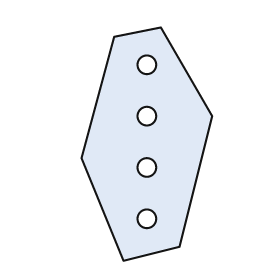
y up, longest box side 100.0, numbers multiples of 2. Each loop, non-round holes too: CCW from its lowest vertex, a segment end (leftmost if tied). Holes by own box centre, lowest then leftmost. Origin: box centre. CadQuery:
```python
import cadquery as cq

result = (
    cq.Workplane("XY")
    .moveTo(-10.0, -50.0)
    .lineTo(14.0, -44.0)
    .lineTo(28.0, 12.0)
    .lineTo(6.0, 50.0)
    .lineTo(-14.0, 46.0)
    .lineTo(-28.0, -6.0)
    .close()
    .moveTo(0.0, -32.0)
    .circle(4.0)
    .moveTo(0.0, -10.0)
    .circle(4.0)
    .moveTo(0.0, 12.0)
    .circle(4.0)
    .moveTo(0.0, 34.0)
    .circle(4.0)
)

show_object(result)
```